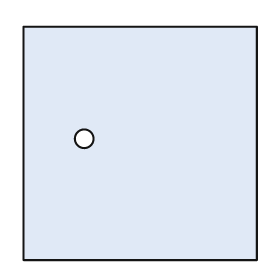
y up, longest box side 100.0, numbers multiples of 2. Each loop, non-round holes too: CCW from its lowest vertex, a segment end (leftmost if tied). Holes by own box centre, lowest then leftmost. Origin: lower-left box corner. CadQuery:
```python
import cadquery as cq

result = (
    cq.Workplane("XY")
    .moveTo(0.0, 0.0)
    .lineTo(100.0, 0.0)
    .lineTo(100.0, 100.0)
    .lineTo(0.0, 100.0)
    .close()
    .moveTo(26.0, 52.0)
    .circle(4.0)
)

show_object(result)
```